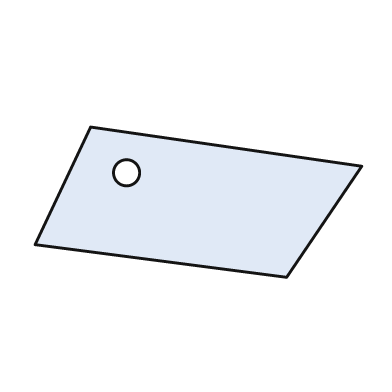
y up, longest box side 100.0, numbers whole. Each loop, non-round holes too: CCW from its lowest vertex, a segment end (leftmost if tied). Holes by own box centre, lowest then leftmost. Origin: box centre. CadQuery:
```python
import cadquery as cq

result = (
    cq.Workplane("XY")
    .moveTo(27.0, -23.0)
    .lineTo(50.0, 11.0)
    .lineTo(-33.0, 23.0)
    .lineTo(-50.0, -13.0)
    .close()
    .moveTo(-22.0, 9.0)
    .circle(4.0)
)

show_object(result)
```